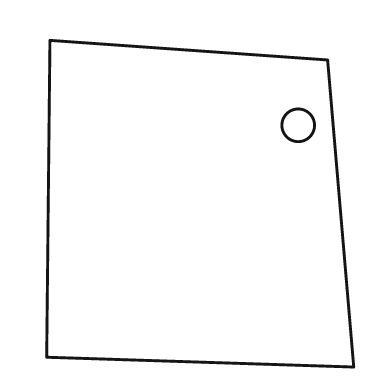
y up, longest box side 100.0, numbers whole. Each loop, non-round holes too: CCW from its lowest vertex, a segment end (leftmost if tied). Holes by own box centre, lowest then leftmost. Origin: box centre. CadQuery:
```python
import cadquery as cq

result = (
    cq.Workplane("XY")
    .moveTo(47.0, -50.0)
    .lineTo(39.0, 44.0)
    .lineTo(-46.0, 50.0)
    .lineTo(-47.0, -47.0)
    .close()
    .moveTo(30.0, 24.0)
    .circle(5.0)
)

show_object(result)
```